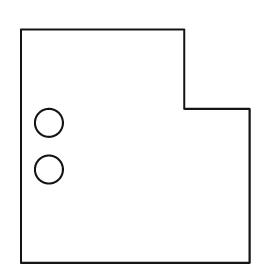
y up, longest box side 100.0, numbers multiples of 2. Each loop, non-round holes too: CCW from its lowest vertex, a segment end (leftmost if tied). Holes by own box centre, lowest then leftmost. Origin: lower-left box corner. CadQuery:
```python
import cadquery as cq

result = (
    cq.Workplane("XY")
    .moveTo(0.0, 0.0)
    .lineTo(98.0, 0.0)
    .lineTo(98.0, 66.0)
    .lineTo(70.0, 66.0)
    .lineTo(70.0, 100.0)
    .lineTo(0.0, 100.0)
    .close()
    .moveTo(12.0, 40.0)
    .circle(6.0)
    .moveTo(12.0, 60.0)
    .circle(6.0)
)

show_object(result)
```